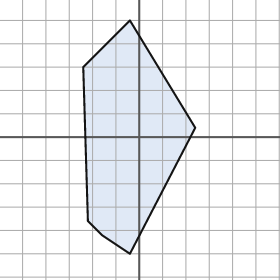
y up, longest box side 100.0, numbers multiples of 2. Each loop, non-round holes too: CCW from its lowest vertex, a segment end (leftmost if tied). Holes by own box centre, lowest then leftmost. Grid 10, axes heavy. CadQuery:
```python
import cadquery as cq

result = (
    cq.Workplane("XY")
    .moveTo(-4.0, -50.0)
    .lineTo(24.0, 4.0)
    .lineTo(-4.0, 50.0)
    .lineTo(-24.0, 30.0)
    .lineTo(-22.0, -36.0)
    .lineTo(-16.0, -42.0)
    .close()
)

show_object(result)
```